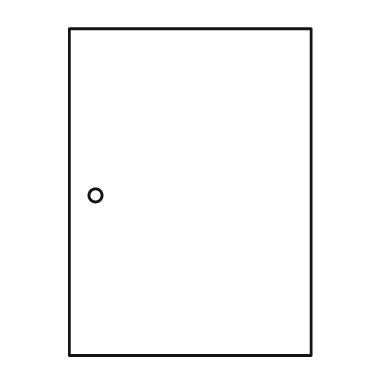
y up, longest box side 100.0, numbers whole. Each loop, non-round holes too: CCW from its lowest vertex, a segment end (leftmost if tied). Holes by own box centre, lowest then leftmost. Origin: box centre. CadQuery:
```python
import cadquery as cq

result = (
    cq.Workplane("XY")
    .moveTo(-37.0, -50.0)
    .lineTo(37.0, -50.0)
    .lineTo(37.0, 50.0)
    .lineTo(-37.0, 50.0)
    .close()
    .moveTo(-29.0, -1.0)
    .circle(2.0)
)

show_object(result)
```